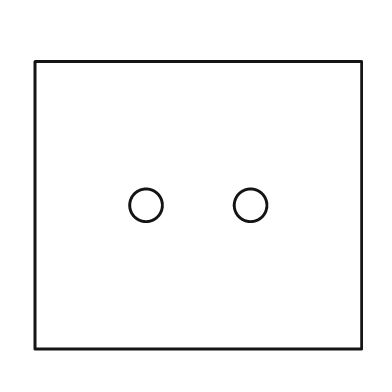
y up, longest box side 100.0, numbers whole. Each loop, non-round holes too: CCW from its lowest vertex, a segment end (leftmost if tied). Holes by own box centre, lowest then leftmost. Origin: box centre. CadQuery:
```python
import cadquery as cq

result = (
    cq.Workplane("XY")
    .moveTo(-50.0, -44.0)
    .lineTo(50.0, -44.0)
    .lineTo(50.0, 44.0)
    .lineTo(-50.0, 44.0)
    .close()
    .moveTo(-16.0, 0.0)
    .circle(5.0)
    .moveTo(16.0, 0.0)
    .circle(5.0)
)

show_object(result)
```